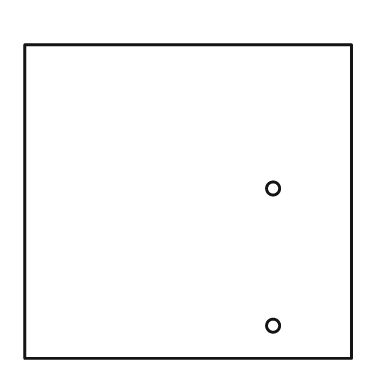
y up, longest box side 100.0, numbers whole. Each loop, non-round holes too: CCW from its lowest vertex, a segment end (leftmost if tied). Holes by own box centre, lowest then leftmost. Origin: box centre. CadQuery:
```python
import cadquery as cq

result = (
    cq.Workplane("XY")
    .moveTo(-50.0, -48.0)
    .lineTo(50.0, -48.0)
    .lineTo(50.0, 48.0)
    .lineTo(-50.0, 48.0)
    .close()
    .moveTo(26.0, -38.0)
    .circle(2.0)
    .moveTo(26.0, 4.0)
    .circle(2.0)
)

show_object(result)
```